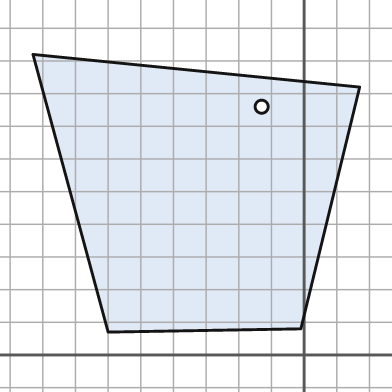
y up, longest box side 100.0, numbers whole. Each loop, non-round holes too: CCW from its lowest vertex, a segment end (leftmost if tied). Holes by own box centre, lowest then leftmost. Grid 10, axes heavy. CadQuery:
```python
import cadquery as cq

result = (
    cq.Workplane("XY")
    .moveTo(-60.0, 7.0)
    .lineTo(-1.0, 8.0)
    .lineTo(17.0, 82.0)
    .lineTo(-83.0, 92.0)
    .close()
    .moveTo(-13.0, 76.0)
    .circle(2.0)
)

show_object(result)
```